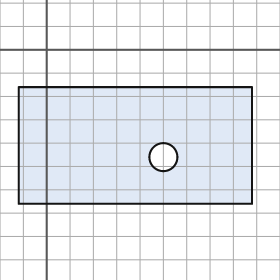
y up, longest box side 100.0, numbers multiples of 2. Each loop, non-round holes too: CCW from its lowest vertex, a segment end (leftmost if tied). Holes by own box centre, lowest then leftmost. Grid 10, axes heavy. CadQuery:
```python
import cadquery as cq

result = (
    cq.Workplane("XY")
    .moveTo(-12.0, -66.0)
    .lineTo(88.0, -66.0)
    .lineTo(88.0, -16.0)
    .lineTo(-12.0, -16.0)
    .close()
    .moveTo(50.0, -46.0)
    .circle(6.0)
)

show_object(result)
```